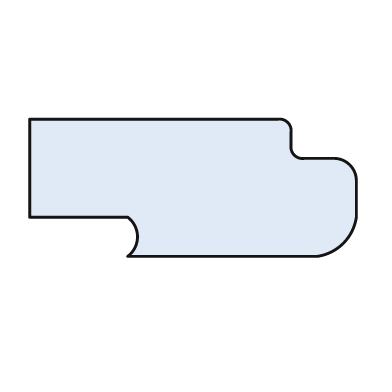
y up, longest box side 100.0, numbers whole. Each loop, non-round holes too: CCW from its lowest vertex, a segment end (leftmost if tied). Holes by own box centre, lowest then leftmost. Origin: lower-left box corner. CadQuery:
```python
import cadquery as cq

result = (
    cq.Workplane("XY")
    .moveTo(30.0, 0.0)
    .lineTo(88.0, 0.0)
    .threePointArc((96.0, 4.0), (100.0, 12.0))
    .lineTo(100.0, 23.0)
    .threePointArc((98.0, 28.0), (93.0, 30.0))
    .lineTo(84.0, 30.0)
    .threePointArc((81.0, 31.0), (80.0, 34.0))
    .lineTo(80.0, 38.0)
    .threePointArc((79.0, 41.0), (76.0, 42.0))
    .lineTo(0.0, 42.0)
    .lineTo(0.0, 12.0)
    .lineTo(30.0, 12.0)
    .threePointArc((33.0, 6.0), (30.0, 0.0))
    .close()
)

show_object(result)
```